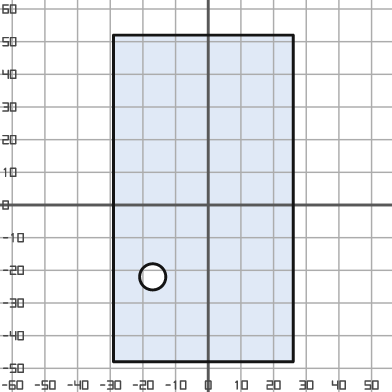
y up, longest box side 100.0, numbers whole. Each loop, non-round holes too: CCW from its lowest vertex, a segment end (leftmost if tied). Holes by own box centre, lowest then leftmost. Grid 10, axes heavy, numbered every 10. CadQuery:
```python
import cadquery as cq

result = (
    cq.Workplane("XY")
    .moveTo(-29.0, -48.0)
    .lineTo(26.0, -48.0)
    .lineTo(26.0, 52.0)
    .lineTo(-29.0, 52.0)
    .close()
    .moveTo(-17.0, -22.0)
    .circle(4.0)
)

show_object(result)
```